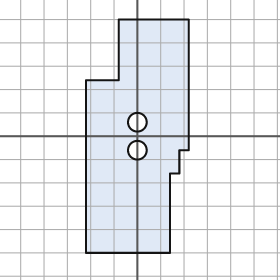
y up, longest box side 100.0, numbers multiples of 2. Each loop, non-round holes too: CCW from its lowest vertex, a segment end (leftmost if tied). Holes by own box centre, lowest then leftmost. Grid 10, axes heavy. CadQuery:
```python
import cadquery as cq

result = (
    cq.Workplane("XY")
    .moveTo(-22.0, -50.0)
    .lineTo(14.0, -50.0)
    .lineTo(14.0, -16.0)
    .lineTo(18.0, -16.0)
    .lineTo(18.0, -6.0)
    .lineTo(22.0, -6.0)
    .lineTo(22.0, 50.0)
    .lineTo(-8.0, 50.0)
    .lineTo(-8.0, 24.0)
    .lineTo(-22.0, 24.0)
    .close()
    .moveTo(0.0, -6.0)
    .circle(4.0)
    .moveTo(0.0, 6.0)
    .circle(4.0)
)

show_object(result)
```